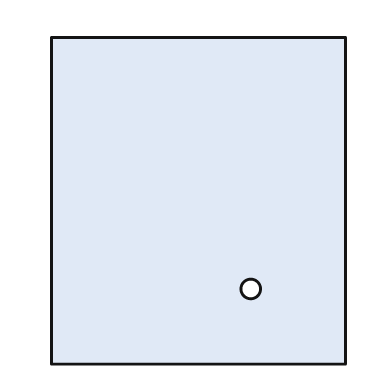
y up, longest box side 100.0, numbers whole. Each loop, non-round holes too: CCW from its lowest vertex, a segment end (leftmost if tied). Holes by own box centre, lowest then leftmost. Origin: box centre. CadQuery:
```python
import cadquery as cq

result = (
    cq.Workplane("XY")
    .moveTo(-45.0, -50.0)
    .lineTo(45.0, -50.0)
    .lineTo(45.0, 50.0)
    .lineTo(-45.0, 50.0)
    .close()
    .moveTo(16.0, -27.0)
    .circle(3.0)
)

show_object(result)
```